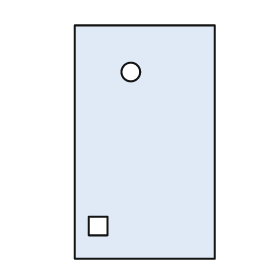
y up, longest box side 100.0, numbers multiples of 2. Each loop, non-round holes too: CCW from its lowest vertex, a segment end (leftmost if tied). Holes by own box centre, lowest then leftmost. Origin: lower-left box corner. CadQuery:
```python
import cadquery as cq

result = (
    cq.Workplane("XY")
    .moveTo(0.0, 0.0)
    .lineTo(60.0, 0.0)
    .lineTo(60.0, 100.0)
    .lineTo(0.0, 100.0)
    .close()
    .moveTo(6.0, 10.0)
    .lineTo(14.0, 10.0)
    .lineTo(14.0, 18.0)
    .lineTo(6.0, 18.0)
    .close()
    .moveTo(24.0, 80.0)
    .circle(4.0)
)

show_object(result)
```